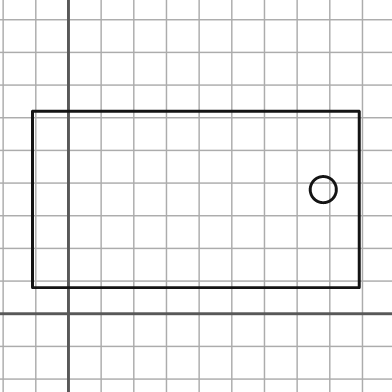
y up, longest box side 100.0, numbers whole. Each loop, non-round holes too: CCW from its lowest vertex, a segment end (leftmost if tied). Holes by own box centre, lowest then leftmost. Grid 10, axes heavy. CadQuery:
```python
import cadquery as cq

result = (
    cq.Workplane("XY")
    .moveTo(-11.0, 8.0)
    .lineTo(89.0, 8.0)
    .lineTo(89.0, 62.0)
    .lineTo(-11.0, 62.0)
    .close()
    .moveTo(78.0, 38.0)
    .circle(4.0)
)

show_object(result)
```